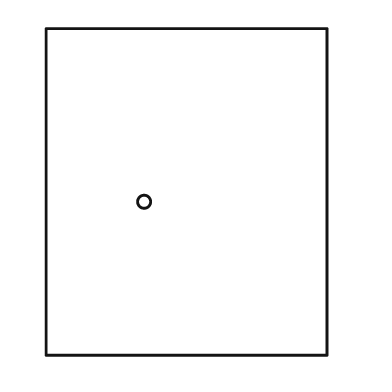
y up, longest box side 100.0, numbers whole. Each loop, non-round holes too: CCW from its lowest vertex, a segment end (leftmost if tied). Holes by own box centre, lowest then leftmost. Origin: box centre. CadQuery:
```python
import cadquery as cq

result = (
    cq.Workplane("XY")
    .moveTo(-43.0, -50.0)
    .lineTo(43.0, -50.0)
    .lineTo(43.0, 50.0)
    .lineTo(-43.0, 50.0)
    .close()
    .moveTo(-13.0, -3.0)
    .circle(2.0)
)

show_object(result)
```